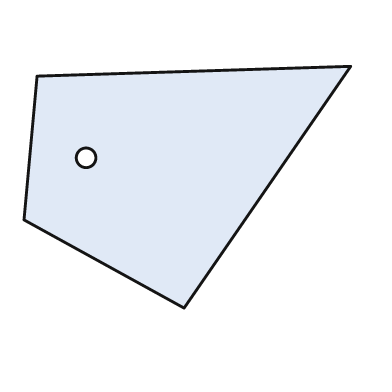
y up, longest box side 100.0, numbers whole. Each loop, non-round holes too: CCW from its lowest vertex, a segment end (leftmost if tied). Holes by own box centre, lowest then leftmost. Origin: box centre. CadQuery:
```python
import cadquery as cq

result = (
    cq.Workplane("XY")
    .moveTo(-1.0, -37.0)
    .lineTo(50.0, 37.0)
    .lineTo(-46.0, 34.0)
    .lineTo(-50.0, -10.0)
    .close()
    .moveTo(-31.0, 9.0)
    .circle(3.0)
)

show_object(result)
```